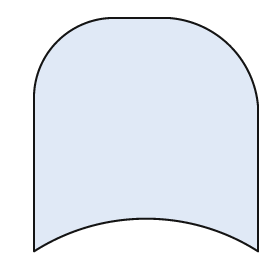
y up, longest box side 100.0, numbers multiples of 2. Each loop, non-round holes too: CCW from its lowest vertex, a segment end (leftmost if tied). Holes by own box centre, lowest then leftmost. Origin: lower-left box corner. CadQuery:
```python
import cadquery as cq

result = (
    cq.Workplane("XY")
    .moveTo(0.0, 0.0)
    .threePointArc((48.0, 14.0), (96.0, 0.0))
    .lineTo(96.0, 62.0)
    .threePointArc((84.0, 88.0), (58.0, 100.0))
    .lineTo(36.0, 100.0)
    .threePointArc((10.0, 90.0), (0.0, 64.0))
    .close()
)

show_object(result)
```